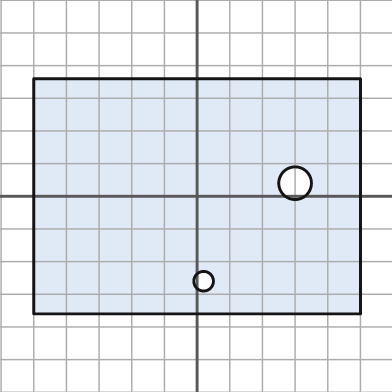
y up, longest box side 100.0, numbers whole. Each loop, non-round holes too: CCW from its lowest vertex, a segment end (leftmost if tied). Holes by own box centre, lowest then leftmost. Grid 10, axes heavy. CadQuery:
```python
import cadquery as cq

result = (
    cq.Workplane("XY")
    .moveTo(-50.0, -36.0)
    .lineTo(50.0, -36.0)
    .lineTo(50.0, 36.0)
    .lineTo(-50.0, 36.0)
    .close()
    .moveTo(2.0, -26.0)
    .circle(3.0)
    .moveTo(30.0, 4.0)
    .circle(5.0)
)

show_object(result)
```